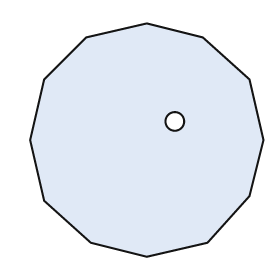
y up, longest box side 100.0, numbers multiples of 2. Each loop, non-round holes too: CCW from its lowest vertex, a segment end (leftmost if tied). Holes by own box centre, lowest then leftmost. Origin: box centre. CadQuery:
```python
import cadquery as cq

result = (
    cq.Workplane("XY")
    .moveTo(0.0, -50.0)
    .lineTo(26.0, -44.0)
    .lineTo(44.0, -24.0)
    .lineTo(50.0, 0.0)
    .lineTo(44.0, 26.0)
    .lineTo(24.0, 44.0)
    .lineTo(0.0, 50.0)
    .lineTo(-26.0, 44.0)
    .lineTo(-44.0, 26.0)
    .lineTo(-50.0, 0.0)
    .lineTo(-44.0, -26.0)
    .lineTo(-24.0, -44.0)
    .close()
    .moveTo(12.0, 8.0)
    .circle(4.0)
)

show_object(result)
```